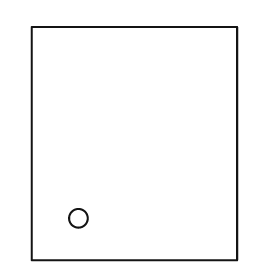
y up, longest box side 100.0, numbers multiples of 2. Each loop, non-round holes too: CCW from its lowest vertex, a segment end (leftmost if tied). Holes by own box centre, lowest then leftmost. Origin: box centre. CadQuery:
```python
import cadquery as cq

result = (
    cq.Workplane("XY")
    .moveTo(-44.0, -50.0)
    .lineTo(44.0, -50.0)
    .lineTo(44.0, 50.0)
    .lineTo(-44.0, 50.0)
    .close()
    .moveTo(-24.0, -32.0)
    .circle(4.0)
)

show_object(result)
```